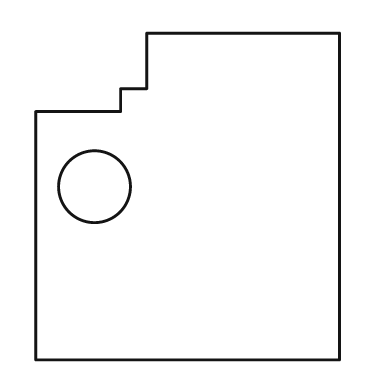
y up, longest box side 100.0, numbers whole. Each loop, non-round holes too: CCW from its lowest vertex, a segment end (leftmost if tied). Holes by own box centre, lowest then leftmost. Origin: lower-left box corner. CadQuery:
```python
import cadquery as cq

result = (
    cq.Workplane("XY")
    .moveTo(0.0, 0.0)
    .lineTo(93.0, 0.0)
    .lineTo(93.0, 100.0)
    .lineTo(34.0, 100.0)
    .lineTo(34.0, 83.0)
    .lineTo(26.0, 83.0)
    .lineTo(26.0, 76.0)
    .lineTo(0.0, 76.0)
    .close()
    .moveTo(18.0, 53.0)
    .circle(11.0)
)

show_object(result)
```